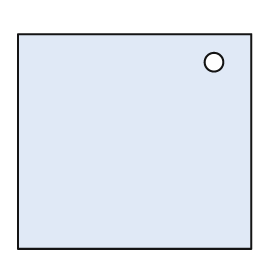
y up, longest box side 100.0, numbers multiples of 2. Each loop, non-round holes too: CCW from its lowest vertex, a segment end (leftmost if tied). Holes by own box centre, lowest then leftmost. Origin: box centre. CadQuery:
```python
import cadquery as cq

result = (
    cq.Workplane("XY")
    .moveTo(-50.0, -46.0)
    .lineTo(50.0, -46.0)
    .lineTo(50.0, 46.0)
    .lineTo(-50.0, 46.0)
    .close()
    .moveTo(34.0, 34.0)
    .circle(4.0)
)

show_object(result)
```